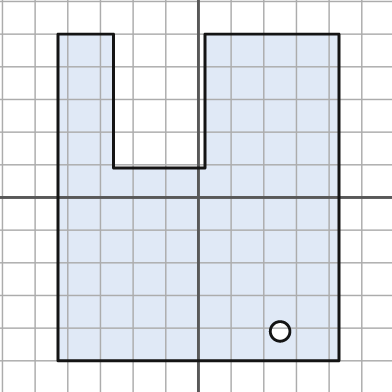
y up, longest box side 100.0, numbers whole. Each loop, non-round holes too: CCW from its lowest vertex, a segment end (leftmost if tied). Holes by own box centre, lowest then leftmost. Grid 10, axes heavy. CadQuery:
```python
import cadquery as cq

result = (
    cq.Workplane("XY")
    .moveTo(-43.0, -50.0)
    .lineTo(43.0, -50.0)
    .lineTo(43.0, 50.0)
    .lineTo(2.0, 50.0)
    .lineTo(2.0, 9.0)
    .lineTo(-26.0, 9.0)
    .lineTo(-26.0, 50.0)
    .lineTo(-43.0, 50.0)
    .close()
    .moveTo(25.0, -41.0)
    .circle(3.0)
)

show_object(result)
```